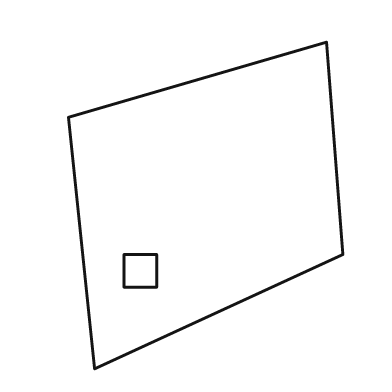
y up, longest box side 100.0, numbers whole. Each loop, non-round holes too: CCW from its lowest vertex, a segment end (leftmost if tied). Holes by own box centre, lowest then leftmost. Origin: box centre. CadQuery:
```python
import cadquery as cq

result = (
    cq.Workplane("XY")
    .moveTo(-34.0, -50.0)
    .lineTo(42.0, -15.0)
    .lineTo(37.0, 50.0)
    .lineTo(-42.0, 27.0)
    .close()
    .moveTo(-25.0, -25.0)
    .lineTo(-15.0, -25.0)
    .lineTo(-15.0, -15.0)
    .lineTo(-25.0, -15.0)
    .close()
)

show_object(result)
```